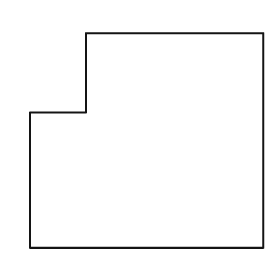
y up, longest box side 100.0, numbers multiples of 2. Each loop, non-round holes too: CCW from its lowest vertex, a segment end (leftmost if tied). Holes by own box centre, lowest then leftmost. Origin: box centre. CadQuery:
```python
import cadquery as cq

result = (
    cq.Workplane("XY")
    .moveTo(-50.0, -46.0)
    .lineTo(50.0, -46.0)
    .lineTo(50.0, 46.0)
    .lineTo(-26.0, 46.0)
    .lineTo(-26.0, 12.0)
    .lineTo(-50.0, 12.0)
    .close()
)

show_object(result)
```